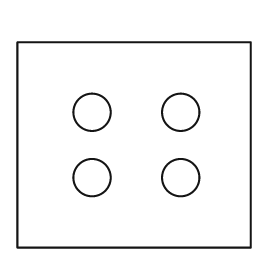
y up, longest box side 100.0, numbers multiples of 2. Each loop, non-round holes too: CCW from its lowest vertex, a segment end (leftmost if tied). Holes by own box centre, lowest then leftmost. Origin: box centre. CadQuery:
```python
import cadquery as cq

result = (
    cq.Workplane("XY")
    .moveTo(-50.0, -44.0)
    .lineTo(50.0, -44.0)
    .lineTo(50.0, 44.0)
    .lineTo(-50.0, 44.0)
    .close()
    .moveTo(-18.0, -14.0)
    .circle(8.0)
    .moveTo(20.0, -14.0)
    .circle(8.0)
    .moveTo(-18.0, 14.0)
    .circle(8.0)
    .moveTo(20.0, 14.0)
    .circle(8.0)
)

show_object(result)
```